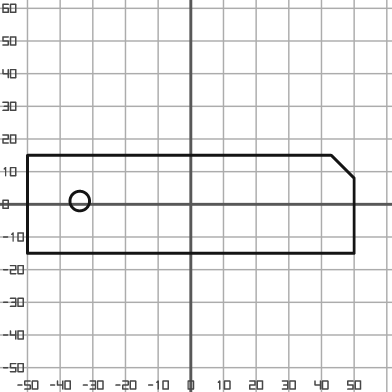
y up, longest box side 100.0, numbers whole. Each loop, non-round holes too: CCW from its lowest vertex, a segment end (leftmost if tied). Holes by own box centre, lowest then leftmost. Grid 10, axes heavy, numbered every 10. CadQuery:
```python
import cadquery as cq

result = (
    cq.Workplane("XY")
    .moveTo(-50.0, -15.0)
    .lineTo(50.0, -15.0)
    .lineTo(50.0, 8.0)
    .lineTo(43.0, 15.0)
    .lineTo(-50.0, 15.0)
    .close()
    .moveTo(-34.0, 1.0)
    .circle(3.0)
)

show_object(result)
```